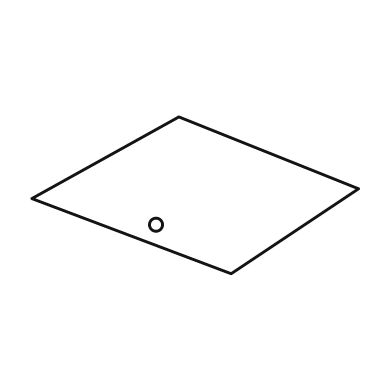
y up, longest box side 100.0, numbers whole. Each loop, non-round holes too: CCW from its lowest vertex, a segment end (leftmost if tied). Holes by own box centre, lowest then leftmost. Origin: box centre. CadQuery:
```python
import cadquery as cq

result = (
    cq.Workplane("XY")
    .moveTo(11.0, -24.0)
    .lineTo(50.0, 2.0)
    .lineTo(-5.0, 24.0)
    .lineTo(-50.0, -1.0)
    .close()
    .moveTo(-12.0, -9.0)
    .circle(2.0)
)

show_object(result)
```